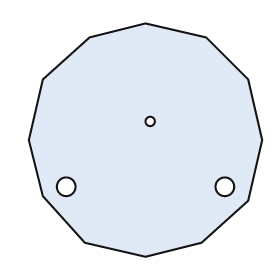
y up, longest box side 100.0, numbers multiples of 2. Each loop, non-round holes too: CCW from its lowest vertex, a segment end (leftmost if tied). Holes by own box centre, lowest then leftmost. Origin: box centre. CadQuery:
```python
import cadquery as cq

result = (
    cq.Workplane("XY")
    .moveTo(0.0, -50.0)
    .lineTo(24.0, -44.0)
    .lineTo(44.0, -26.0)
    .lineTo(50.0, 0.0)
    .lineTo(44.0, 26.0)
    .lineTo(26.0, 44.0)
    .lineTo(0.0, 50.0)
    .lineTo(-24.0, 44.0)
    .lineTo(-44.0, 26.0)
    .lineTo(-50.0, 0.0)
    .lineTo(-44.0, -24.0)
    .lineTo(-26.0, -44.0)
    .close()
    .moveTo(-34.0, -20.0)
    .circle(4.0)
    .moveTo(34.0, -20.0)
    .circle(4.0)
    .moveTo(2.0, 8.0)
    .circle(2.0)
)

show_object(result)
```